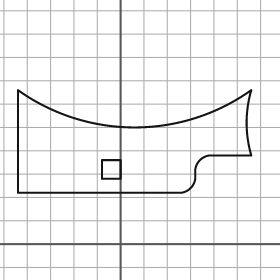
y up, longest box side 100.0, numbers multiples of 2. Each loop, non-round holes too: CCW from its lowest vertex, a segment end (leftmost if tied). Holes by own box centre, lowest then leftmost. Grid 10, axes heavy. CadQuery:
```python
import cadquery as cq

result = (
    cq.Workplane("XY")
    .moveTo(-44.0, 22.0)
    .lineTo(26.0, 22.0)
    .threePointArc((30.0, 24.0), (32.0, 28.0))
    .lineTo(32.0, 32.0)
    .threePointArc((34.0, 36.0), (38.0, 38.0))
    .lineTo(56.0, 38.0)
    .threePointArc((54.0, 52.0), (56.0, 66.0))
    .threePointArc((6.0, 50.0), (-44.0, 66.0))
    .close()
    .moveTo(-8.0, 28.0)
    .lineTo(0.0, 28.0)
    .lineTo(0.0, 36.0)
    .lineTo(-8.0, 36.0)
    .close()
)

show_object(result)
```